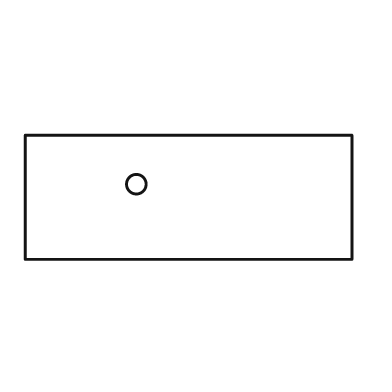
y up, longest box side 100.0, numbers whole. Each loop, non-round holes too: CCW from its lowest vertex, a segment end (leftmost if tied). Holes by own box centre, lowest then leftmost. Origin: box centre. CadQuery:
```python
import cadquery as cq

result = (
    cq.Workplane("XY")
    .moveTo(-50.0, -19.0)
    .lineTo(50.0, -19.0)
    .lineTo(50.0, 19.0)
    .lineTo(-50.0, 19.0)
    .close()
    .moveTo(-16.0, 4.0)
    .circle(3.0)
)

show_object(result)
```